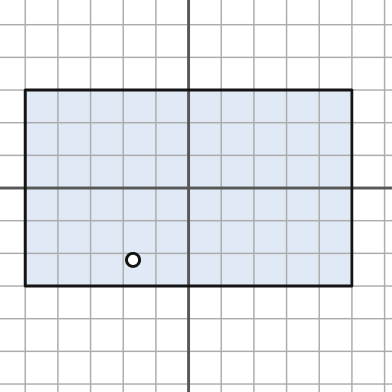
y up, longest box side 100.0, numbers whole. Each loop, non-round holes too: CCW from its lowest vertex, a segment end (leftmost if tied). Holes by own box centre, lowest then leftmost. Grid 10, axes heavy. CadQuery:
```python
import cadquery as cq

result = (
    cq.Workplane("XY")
    .moveTo(-50.0, -30.0)
    .lineTo(50.0, -30.0)
    .lineTo(50.0, 30.0)
    .lineTo(-50.0, 30.0)
    .close()
    .moveTo(-17.0, -22.0)
    .circle(2.0)
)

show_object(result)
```